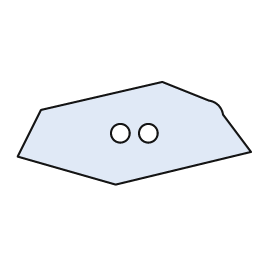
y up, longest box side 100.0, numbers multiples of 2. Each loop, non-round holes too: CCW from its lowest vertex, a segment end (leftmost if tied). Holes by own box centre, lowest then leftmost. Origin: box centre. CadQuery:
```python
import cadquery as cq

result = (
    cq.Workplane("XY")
    .moveTo(-8.0, -22.0)
    .lineTo(50.0, -8.0)
    .lineTo(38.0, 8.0)
    .threePointArc((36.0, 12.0), (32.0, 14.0))
    .lineTo(12.0, 22.0)
    .lineTo(-40.0, 10.0)
    .lineTo(-50.0, -10.0)
    .close()
    .moveTo(-6.0, 0.0)
    .circle(4.0)
    .moveTo(6.0, 0.0)
    .circle(4.0)
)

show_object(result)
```